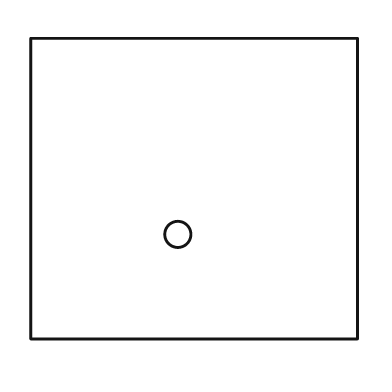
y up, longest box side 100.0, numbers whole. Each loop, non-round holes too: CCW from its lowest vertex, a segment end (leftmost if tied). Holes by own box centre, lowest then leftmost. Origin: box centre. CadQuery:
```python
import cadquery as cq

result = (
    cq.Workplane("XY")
    .moveTo(-50.0, -46.0)
    .lineTo(50.0, -46.0)
    .lineTo(50.0, 46.0)
    .lineTo(-50.0, 46.0)
    .close()
    .moveTo(-5.0, -14.0)
    .circle(4.0)
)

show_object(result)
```